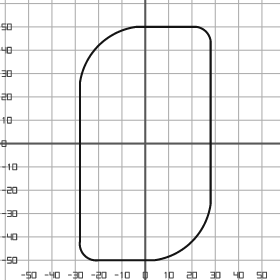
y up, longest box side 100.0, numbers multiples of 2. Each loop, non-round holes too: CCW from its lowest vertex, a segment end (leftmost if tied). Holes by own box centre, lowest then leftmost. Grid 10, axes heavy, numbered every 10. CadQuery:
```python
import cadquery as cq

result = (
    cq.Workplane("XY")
    .moveTo(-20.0, -50.0)
    .lineTo(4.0, -50.0)
    .threePointArc((20.0, -42.0), (28.0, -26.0))
    .lineTo(28.0, 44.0)
    .threePointArc((26.0, 48.0), (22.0, 50.0))
    .lineTo(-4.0, 50.0)
    .threePointArc((-20.0, 42.0), (-28.0, 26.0))
    .lineTo(-28.0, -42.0)
    .threePointArc((-26.0, -48.0), (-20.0, -50.0))
    .close()
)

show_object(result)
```